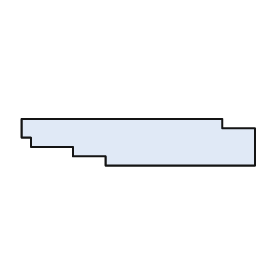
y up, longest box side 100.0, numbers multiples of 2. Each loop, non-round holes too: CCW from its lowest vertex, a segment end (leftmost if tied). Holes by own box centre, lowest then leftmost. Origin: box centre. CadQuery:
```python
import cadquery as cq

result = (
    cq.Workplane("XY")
    .moveTo(-14.0, -10.0)
    .lineTo(50.0, -10.0)
    .lineTo(50.0, 6.0)
    .lineTo(36.0, 6.0)
    .lineTo(36.0, 10.0)
    .lineTo(-50.0, 10.0)
    .lineTo(-50.0, 2.0)
    .lineTo(-46.0, 2.0)
    .lineTo(-46.0, -2.0)
    .lineTo(-28.0, -2.0)
    .lineTo(-28.0, -6.0)
    .lineTo(-14.0, -6.0)
    .close()
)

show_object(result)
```